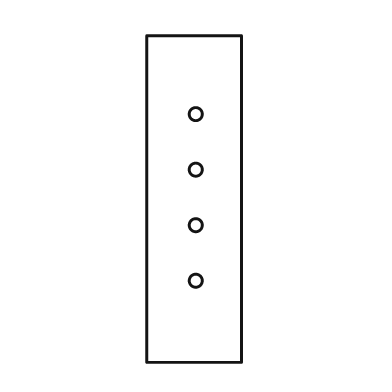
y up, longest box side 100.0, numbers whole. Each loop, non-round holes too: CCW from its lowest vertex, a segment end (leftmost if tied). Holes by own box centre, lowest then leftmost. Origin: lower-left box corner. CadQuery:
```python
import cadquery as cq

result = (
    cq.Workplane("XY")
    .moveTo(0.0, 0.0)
    .lineTo(29.0, 0.0)
    .lineTo(29.0, 100.0)
    .lineTo(0.0, 100.0)
    .close()
    .moveTo(15.0, 25.0)
    .circle(2.0)
    .moveTo(15.0, 42.0)
    .circle(2.0)
    .moveTo(15.0, 59.0)
    .circle(2.0)
    .moveTo(15.0, 76.0)
    .circle(2.0)
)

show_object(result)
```